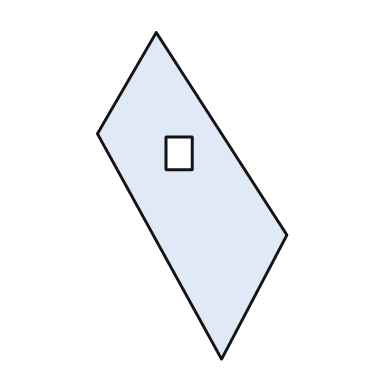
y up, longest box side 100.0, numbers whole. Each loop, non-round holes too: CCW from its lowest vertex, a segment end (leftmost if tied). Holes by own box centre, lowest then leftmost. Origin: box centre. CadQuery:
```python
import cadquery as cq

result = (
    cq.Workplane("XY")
    .moveTo(9.0, -50.0)
    .lineTo(29.0, -12.0)
    .lineTo(-11.0, 50.0)
    .lineTo(-29.0, 19.0)
    .close()
    .moveTo(-8.0, 8.0)
    .lineTo(0.0, 8.0)
    .lineTo(0.0, 18.0)
    .lineTo(-8.0, 18.0)
    .close()
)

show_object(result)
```